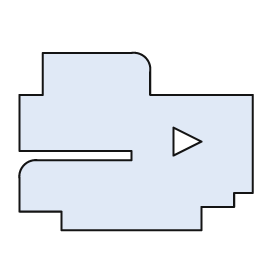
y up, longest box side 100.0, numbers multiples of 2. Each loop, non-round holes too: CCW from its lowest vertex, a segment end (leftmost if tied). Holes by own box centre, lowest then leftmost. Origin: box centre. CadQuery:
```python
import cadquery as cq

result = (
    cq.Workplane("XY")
    .moveTo(-32.0, -38.0)
    .lineTo(28.0, -38.0)
    .lineTo(28.0, -28.0)
    .lineTo(42.0, -28.0)
    .lineTo(42.0, -22.0)
    .lineTo(50.0, -22.0)
    .lineTo(50.0, 20.0)
    .lineTo(6.0, 20.0)
    .lineTo(6.0, 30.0)
    .threePointArc((4.0, 36.0), (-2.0, 38.0))
    .lineTo(-40.0, 38.0)
    .lineTo(-40.0, 20.0)
    .lineTo(-50.0, 20.0)
    .lineTo(-50.0, -4.0)
    .lineTo(-2.0, -4.0)
    .lineTo(-2.0, -8.0)
    .lineTo(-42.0, -8.0)
    .threePointArc((-48.0, -10.0), (-50.0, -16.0))
    .lineTo(-50.0, -30.0)
    .lineTo(-32.0, -30.0)
    .close()
    .moveTo(16.0, -6.0)
    .lineTo(28.0, 0.0)
    .lineTo(16.0, 6.0)
    .close()
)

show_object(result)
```